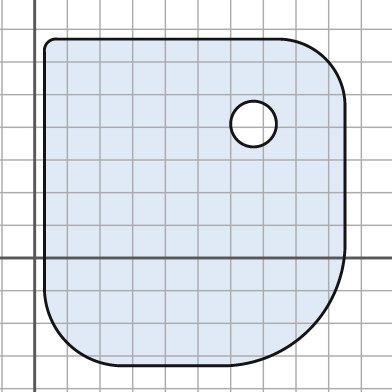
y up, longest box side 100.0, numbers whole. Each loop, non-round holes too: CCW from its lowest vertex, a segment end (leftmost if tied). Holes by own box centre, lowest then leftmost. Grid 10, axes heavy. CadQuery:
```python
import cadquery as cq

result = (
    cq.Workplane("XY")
    .moveTo(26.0, -33.0)
    .lineTo(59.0, -33.0)
    .threePointArc((84.0, -22.0), (95.0, 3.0))
    .lineTo(95.0, 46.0)
    .threePointArc((89.0, 61.0), (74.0, 67.0))
    .lineTo(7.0, 67.0)
    .threePointArc((4.0, 66.0), (3.0, 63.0))
    .lineTo(3.0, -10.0)
    .threePointArc((10.0, -26.0), (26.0, -33.0))
    .close()
    .moveTo(67.0, 41.0)
    .circle(7.0)
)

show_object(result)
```